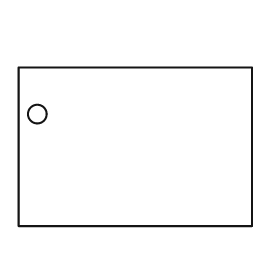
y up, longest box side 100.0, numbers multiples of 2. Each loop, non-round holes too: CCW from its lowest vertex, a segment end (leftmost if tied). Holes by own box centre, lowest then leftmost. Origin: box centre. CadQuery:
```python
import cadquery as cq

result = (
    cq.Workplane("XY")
    .moveTo(-50.0, -34.0)
    .lineTo(50.0, -34.0)
    .lineTo(50.0, 34.0)
    .lineTo(-50.0, 34.0)
    .close()
    .moveTo(-42.0, 14.0)
    .circle(4.0)
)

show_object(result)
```